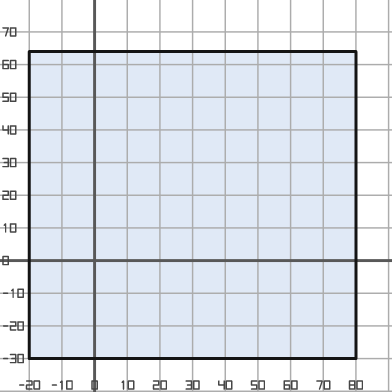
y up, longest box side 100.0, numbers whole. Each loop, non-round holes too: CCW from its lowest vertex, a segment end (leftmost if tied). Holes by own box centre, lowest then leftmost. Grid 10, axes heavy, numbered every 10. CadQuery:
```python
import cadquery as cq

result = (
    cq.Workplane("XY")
    .moveTo(-20.0, -30.0)
    .lineTo(80.0, -30.0)
    .lineTo(80.0, 64.0)
    .lineTo(-20.0, 64.0)
    .close()
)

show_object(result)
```